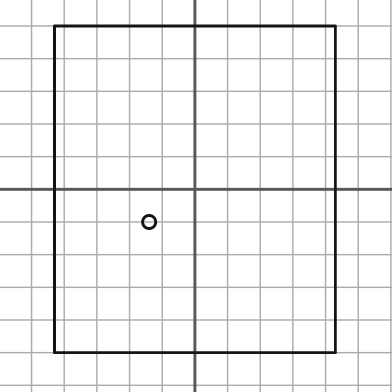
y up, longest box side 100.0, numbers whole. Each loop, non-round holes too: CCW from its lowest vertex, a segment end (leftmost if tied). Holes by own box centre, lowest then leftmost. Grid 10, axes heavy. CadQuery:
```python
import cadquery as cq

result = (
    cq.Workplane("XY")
    .moveTo(-43.0, -50.0)
    .lineTo(43.0, -50.0)
    .lineTo(43.0, 50.0)
    .lineTo(-43.0, 50.0)
    .close()
    .moveTo(-14.0, -10.0)
    .circle(2.0)
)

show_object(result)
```